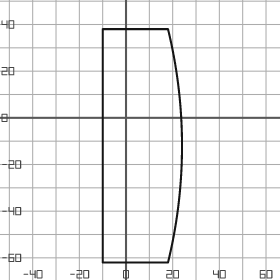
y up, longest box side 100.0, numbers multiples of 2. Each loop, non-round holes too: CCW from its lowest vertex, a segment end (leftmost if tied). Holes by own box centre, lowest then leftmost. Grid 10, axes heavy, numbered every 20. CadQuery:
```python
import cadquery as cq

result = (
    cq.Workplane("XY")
    .moveTo(-10.0, -62.0)
    .lineTo(18.0, -62.0)
    .threePointArc((24.0, -12.0), (18.0, 38.0))
    .lineTo(-10.0, 38.0)
    .close()
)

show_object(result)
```